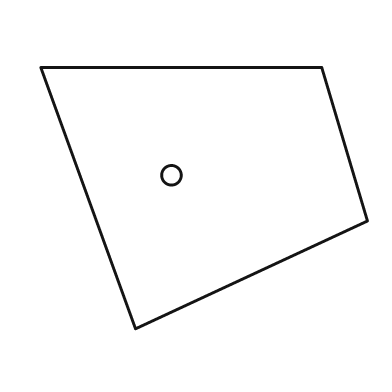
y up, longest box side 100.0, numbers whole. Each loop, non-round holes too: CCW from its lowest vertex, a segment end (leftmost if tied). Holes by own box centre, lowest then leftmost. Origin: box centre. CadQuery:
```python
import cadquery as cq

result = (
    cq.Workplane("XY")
    .moveTo(-21.0, -40.0)
    .lineTo(50.0, -7.0)
    .lineTo(36.0, 40.0)
    .lineTo(-50.0, 40.0)
    .close()
    .moveTo(-10.0, 7.0)
    .circle(3.0)
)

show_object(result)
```